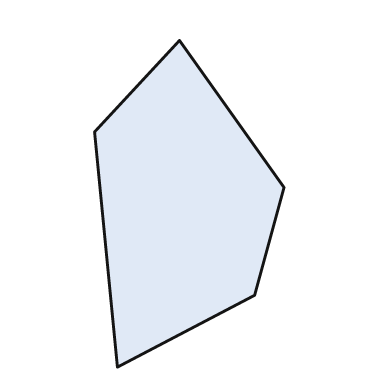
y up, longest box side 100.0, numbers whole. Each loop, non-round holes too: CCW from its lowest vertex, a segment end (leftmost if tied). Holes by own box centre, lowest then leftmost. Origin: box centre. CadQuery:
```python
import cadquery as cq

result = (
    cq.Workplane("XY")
    .moveTo(-22.0, -50.0)
    .lineTo(20.0, -28.0)
    .lineTo(29.0, 5.0)
    .lineTo(-3.0, 50.0)
    .lineTo(-29.0, 22.0)
    .close()
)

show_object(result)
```